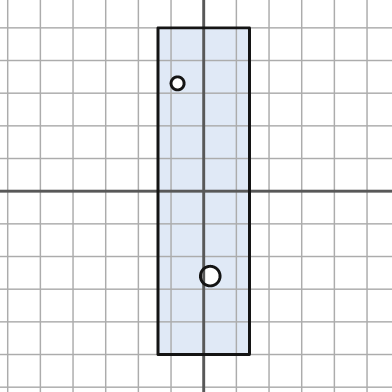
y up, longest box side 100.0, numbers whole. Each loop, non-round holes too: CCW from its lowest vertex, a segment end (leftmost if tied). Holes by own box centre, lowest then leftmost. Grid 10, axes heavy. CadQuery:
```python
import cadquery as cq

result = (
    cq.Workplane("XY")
    .moveTo(-14.0, -50.0)
    .lineTo(14.0, -50.0)
    .lineTo(14.0, 50.0)
    .lineTo(-14.0, 50.0)
    .close()
    .moveTo(2.0, -26.0)
    .circle(3.0)
    .moveTo(-8.0, 33.0)
    .circle(2.0)
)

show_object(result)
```